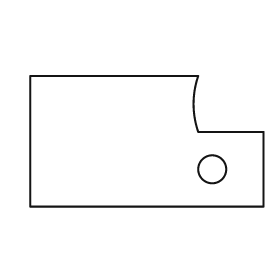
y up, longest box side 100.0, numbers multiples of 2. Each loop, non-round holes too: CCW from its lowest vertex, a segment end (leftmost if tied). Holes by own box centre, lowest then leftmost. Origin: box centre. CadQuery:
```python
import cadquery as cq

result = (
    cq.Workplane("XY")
    .moveTo(-50.0, -28.0)
    .lineTo(50.0, -28.0)
    .lineTo(50.0, 4.0)
    .lineTo(22.0, 4.0)
    .threePointArc((20.0, 16.0), (22.0, 28.0))
    .lineTo(-50.0, 28.0)
    .close()
    .moveTo(28.0, -12.0)
    .circle(6.0)
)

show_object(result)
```